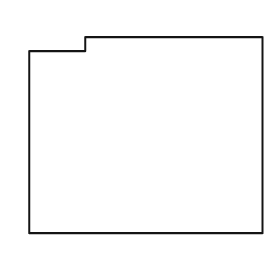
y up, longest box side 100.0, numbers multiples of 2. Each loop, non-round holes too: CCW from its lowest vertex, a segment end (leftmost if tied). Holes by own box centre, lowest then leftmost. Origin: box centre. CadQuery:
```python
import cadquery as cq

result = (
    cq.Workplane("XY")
    .moveTo(-50.0, -42.0)
    .lineTo(50.0, -42.0)
    .lineTo(50.0, 42.0)
    .lineTo(-26.0, 42.0)
    .lineTo(-26.0, 36.0)
    .lineTo(-50.0, 36.0)
    .close()
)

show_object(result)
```